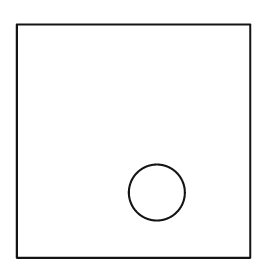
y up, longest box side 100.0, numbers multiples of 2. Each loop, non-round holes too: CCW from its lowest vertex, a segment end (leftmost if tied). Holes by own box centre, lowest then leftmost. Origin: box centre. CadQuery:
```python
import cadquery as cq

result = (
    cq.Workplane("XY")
    .moveTo(-50.0, -50.0)
    .lineTo(50.0, -50.0)
    .lineTo(50.0, 50.0)
    .lineTo(-50.0, 50.0)
    .close()
    .moveTo(10.0, -22.0)
    .circle(12.0)
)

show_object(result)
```